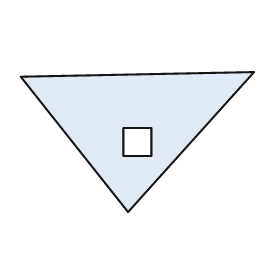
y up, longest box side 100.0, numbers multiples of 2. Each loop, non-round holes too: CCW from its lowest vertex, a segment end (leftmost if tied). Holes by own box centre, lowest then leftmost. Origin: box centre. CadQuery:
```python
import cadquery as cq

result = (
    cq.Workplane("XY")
    .moveTo(-4.0, -30.0)
    .lineTo(50.0, 30.0)
    .lineTo(-50.0, 28.0)
    .close()
    .moveTo(-6.0, -6.0)
    .lineTo(6.0, -6.0)
    .lineTo(6.0, 6.0)
    .lineTo(-6.0, 6.0)
    .close()
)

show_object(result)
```